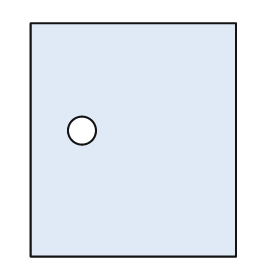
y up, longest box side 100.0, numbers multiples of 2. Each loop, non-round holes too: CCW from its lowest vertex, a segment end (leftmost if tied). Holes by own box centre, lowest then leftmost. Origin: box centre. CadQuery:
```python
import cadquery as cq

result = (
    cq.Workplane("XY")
    .moveTo(-44.0, -50.0)
    .lineTo(44.0, -50.0)
    .lineTo(44.0, 50.0)
    .lineTo(-44.0, 50.0)
    .close()
    .moveTo(-22.0, 4.0)
    .circle(6.0)
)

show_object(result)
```